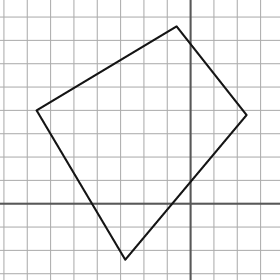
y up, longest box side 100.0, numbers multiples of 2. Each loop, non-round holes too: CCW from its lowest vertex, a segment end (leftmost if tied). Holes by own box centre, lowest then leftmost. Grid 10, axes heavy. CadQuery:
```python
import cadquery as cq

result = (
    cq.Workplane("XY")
    .moveTo(-28.0, -24.0)
    .lineTo(24.0, 38.0)
    .lineTo(-6.0, 76.0)
    .lineTo(-66.0, 40.0)
    .close()
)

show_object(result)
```